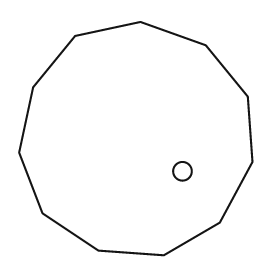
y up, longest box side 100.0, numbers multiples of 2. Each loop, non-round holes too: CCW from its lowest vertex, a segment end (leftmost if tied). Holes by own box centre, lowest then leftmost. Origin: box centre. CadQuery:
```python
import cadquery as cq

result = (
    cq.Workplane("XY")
    .moveTo(12.0, -50.0)
    .lineTo(36.0, -36.0)
    .lineTo(50.0, -10.0)
    .lineTo(48.0, 18.0)
    .lineTo(30.0, 40.0)
    .lineTo(2.0, 50.0)
    .lineTo(-26.0, 44.0)
    .lineTo(-44.0, 22.0)
    .lineTo(-50.0, -6.0)
    .lineTo(-40.0, -32.0)
    .lineTo(-16.0, -48.0)
    .close()
    .moveTo(20.0, -14.0)
    .circle(4.0)
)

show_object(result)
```